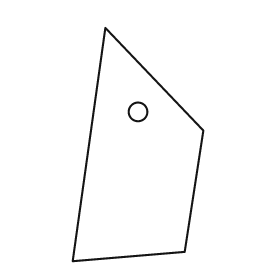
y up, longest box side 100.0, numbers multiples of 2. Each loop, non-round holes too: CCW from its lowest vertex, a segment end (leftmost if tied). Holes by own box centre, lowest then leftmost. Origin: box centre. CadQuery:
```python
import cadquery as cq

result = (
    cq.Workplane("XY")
    .moveTo(-28.0, -50.0)
    .lineTo(20.0, -46.0)
    .lineTo(28.0, 6.0)
    .lineTo(-14.0, 50.0)
    .close()
    .moveTo(0.0, 14.0)
    .circle(4.0)
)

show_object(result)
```